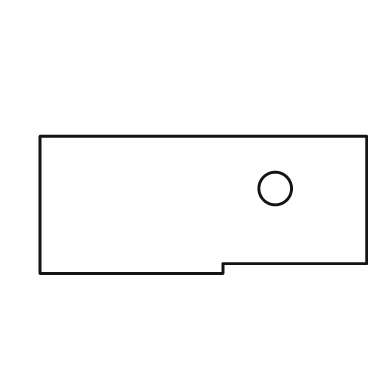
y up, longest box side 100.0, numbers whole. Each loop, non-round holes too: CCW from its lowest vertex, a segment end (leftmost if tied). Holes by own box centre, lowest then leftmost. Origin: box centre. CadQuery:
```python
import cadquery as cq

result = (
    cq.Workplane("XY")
    .moveTo(-50.0, -21.0)
    .lineTo(6.0, -21.0)
    .lineTo(6.0, -18.0)
    .lineTo(50.0, -18.0)
    .lineTo(50.0, 21.0)
    .lineTo(-50.0, 21.0)
    .close()
    .moveTo(22.0, 5.0)
    .circle(5.0)
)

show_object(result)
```